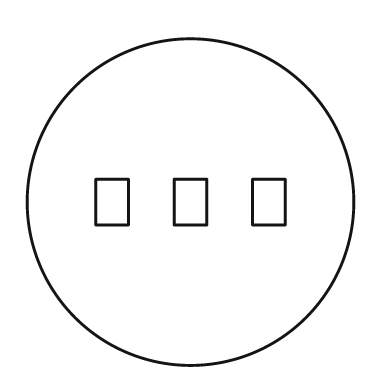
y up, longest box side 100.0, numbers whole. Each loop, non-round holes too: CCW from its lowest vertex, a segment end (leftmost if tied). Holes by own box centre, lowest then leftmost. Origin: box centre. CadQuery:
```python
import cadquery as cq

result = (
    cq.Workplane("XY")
    .moveTo(0.0, 0.0)
    .circle(50.0)
    .moveTo(-29.0, -7.0)
    .lineTo(-19.0, -7.0)
    .lineTo(-19.0, 7.0)
    .lineTo(-29.0, 7.0)
    .close()
    .moveTo(-5.0, -7.0)
    .lineTo(5.0, -7.0)
    .lineTo(5.0, 7.0)
    .lineTo(-5.0, 7.0)
    .close()
    .moveTo(19.0, -7.0)
    .lineTo(29.0, -7.0)
    .lineTo(29.0, 7.0)
    .lineTo(19.0, 7.0)
    .close()
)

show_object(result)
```